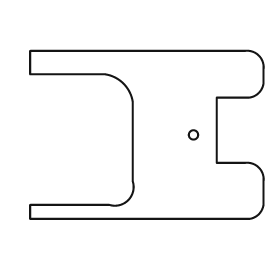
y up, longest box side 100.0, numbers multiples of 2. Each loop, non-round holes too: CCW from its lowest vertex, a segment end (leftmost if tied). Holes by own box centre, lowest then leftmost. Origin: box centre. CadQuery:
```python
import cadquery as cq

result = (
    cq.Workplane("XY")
    .moveTo(-50.0, -36.0)
    .lineTo(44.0, -36.0)
    .threePointArc((48.0, -34.0), (50.0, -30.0))
    .lineTo(50.0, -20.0)
    .threePointArc((48.0, -14.0), (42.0, -12.0))
    .lineTo(30.0, -12.0)
    .lineTo(30.0, 16.0)
    .lineTo(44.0, 16.0)
    .threePointArc((48.0, 18.0), (50.0, 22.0))
    .lineTo(50.0, 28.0)
    .threePointArc((48.0, 34.0), (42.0, 36.0))
    .lineTo(-50.0, 36.0)
    .lineTo(-50.0, 26.0)
    .lineTo(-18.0, 26.0)
    .threePointArc((-10.0, 22.0), (-6.0, 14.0))
    .lineTo(-6.0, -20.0)
    .threePointArc((-8.0, -28.0), (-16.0, -30.0))
    .lineTo(-50.0, -30.0)
    .close()
    .moveTo(20.0, 0.0)
    .circle(2.0)
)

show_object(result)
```